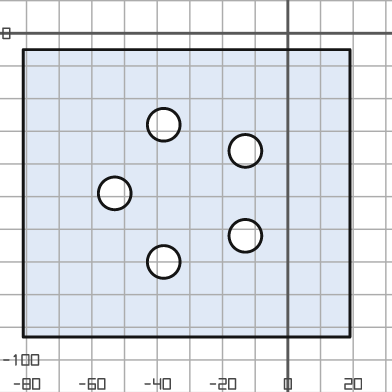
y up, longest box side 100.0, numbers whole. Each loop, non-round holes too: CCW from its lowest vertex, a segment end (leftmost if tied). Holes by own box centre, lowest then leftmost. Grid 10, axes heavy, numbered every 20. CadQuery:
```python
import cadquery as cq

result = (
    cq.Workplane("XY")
    .moveTo(-81.0, -93.0)
    .lineTo(19.0, -93.0)
    .lineTo(19.0, -5.0)
    .lineTo(-81.0, -5.0)
    .close()
    .moveTo(-38.0, -70.0)
    .circle(5.0)
    .moveTo(-13.0, -62.0)
    .circle(5.0)
    .moveTo(-53.0, -49.0)
    .circle(5.0)
    .moveTo(-13.0, -36.0)
    .circle(5.0)
    .moveTo(-38.0, -28.0)
    .circle(5.0)
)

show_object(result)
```